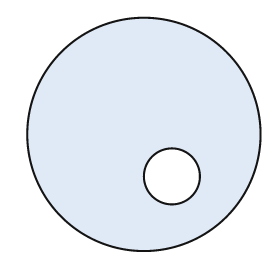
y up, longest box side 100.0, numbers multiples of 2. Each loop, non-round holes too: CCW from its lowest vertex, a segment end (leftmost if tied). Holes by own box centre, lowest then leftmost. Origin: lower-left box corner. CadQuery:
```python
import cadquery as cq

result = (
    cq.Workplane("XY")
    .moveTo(50.0, 50.0)
    .circle(50.0)
    .moveTo(62.0, 32.0)
    .circle(12.0)
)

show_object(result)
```